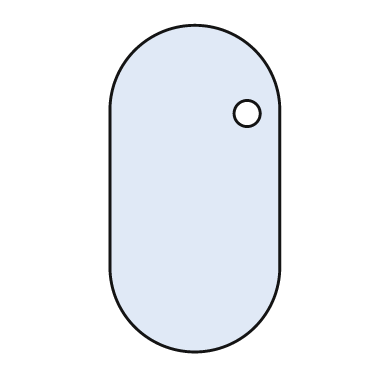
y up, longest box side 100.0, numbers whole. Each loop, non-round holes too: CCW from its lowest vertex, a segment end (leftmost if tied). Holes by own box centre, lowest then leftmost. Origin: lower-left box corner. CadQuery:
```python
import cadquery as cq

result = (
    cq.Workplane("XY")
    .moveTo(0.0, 26.0)
    .threePointArc((26.0, 0.0), (52.0, 26.0))
    .lineTo(52.0, 74.0)
    .threePointArc((26.0, 100.0), (0.0, 74.0))
    .close()
    .moveTo(42.0, 73.0)
    .circle(4.0)
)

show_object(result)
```